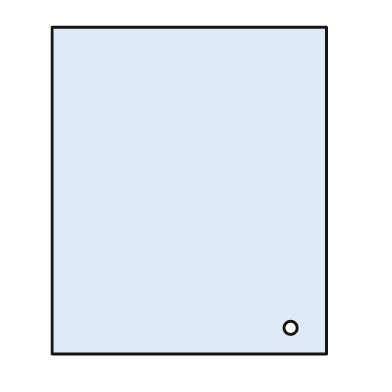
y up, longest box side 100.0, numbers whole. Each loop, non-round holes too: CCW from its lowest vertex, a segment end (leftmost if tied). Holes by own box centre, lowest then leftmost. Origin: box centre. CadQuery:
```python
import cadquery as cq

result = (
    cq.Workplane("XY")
    .moveTo(-42.0, -50.0)
    .lineTo(42.0, -50.0)
    .lineTo(42.0, 50.0)
    .lineTo(-42.0, 50.0)
    .close()
    .moveTo(31.0, -42.0)
    .circle(2.0)
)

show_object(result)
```